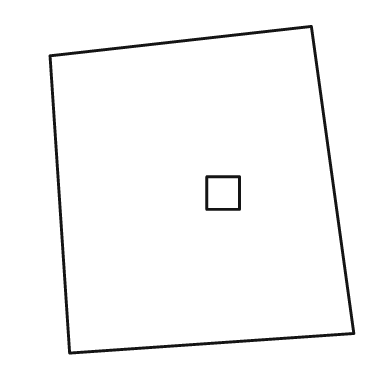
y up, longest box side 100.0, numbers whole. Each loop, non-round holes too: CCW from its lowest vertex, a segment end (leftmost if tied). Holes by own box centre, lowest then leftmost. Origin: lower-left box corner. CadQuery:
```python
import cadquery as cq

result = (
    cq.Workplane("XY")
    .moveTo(6.0, 0.0)
    .lineTo(93.0, 6.0)
    .lineTo(80.0, 100.0)
    .lineTo(0.0, 91.0)
    .close()
    .moveTo(48.0, 44.0)
    .lineTo(58.0, 44.0)
    .lineTo(58.0, 54.0)
    .lineTo(48.0, 54.0)
    .close()
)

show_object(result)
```